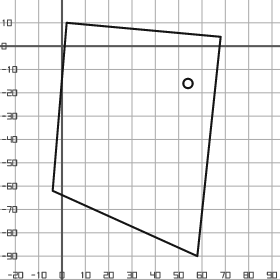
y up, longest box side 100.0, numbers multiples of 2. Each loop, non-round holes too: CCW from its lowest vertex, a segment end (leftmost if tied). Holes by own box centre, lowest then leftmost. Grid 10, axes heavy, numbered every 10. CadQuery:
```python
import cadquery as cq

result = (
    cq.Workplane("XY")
    .moveTo(58.0, -90.0)
    .lineTo(68.0, 4.0)
    .lineTo(2.0, 10.0)
    .lineTo(-4.0, -62.0)
    .close()
    .moveTo(54.0, -16.0)
    .circle(2.0)
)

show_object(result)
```